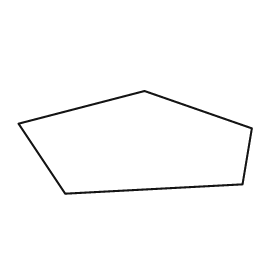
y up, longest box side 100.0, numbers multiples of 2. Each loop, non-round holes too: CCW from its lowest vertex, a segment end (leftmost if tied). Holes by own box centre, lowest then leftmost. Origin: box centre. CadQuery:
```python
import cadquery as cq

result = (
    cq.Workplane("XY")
    .moveTo(-30.0, -22.0)
    .lineTo(46.0, -18.0)
    .lineTo(50.0, 6.0)
    .lineTo(4.0, 22.0)
    .lineTo(-50.0, 8.0)
    .close()
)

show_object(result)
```